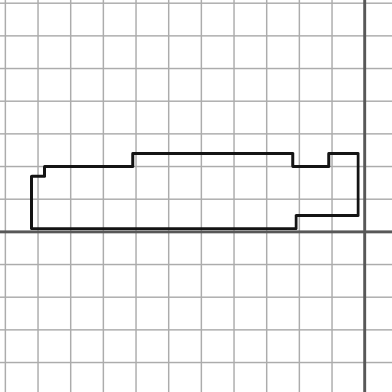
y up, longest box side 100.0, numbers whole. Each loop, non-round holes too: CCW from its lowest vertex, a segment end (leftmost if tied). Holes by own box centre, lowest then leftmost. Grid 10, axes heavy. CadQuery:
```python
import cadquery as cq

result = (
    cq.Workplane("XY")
    .moveTo(-102.0, 1.0)
    .lineTo(-21.0, 1.0)
    .lineTo(-21.0, 5.0)
    .lineTo(-2.0, 5.0)
    .lineTo(-2.0, 24.0)
    .lineTo(-11.0, 24.0)
    .lineTo(-11.0, 20.0)
    .lineTo(-22.0, 20.0)
    .lineTo(-22.0, 24.0)
    .lineTo(-71.0, 24.0)
    .lineTo(-71.0, 20.0)
    .lineTo(-98.0, 20.0)
    .lineTo(-98.0, 17.0)
    .lineTo(-102.0, 17.0)
    .close()
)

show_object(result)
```